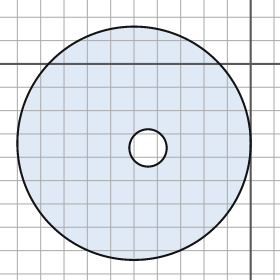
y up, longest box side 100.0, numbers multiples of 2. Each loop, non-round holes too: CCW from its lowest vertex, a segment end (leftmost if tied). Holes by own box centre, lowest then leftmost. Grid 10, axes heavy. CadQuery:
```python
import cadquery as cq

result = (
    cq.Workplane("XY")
    .moveTo(-50.0, -34.0)
    .circle(50.0)
    .moveTo(-44.0, -36.0)
    .circle(8.0)
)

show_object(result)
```